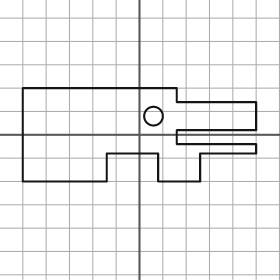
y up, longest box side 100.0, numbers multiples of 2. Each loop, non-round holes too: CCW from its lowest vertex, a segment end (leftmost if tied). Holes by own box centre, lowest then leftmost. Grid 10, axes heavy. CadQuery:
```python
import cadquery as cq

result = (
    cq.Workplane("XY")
    .moveTo(-50.0, -20.0)
    .lineTo(-14.0, -20.0)
    .lineTo(-14.0, -8.0)
    .lineTo(8.0, -8.0)
    .lineTo(8.0, -20.0)
    .lineTo(26.0, -20.0)
    .lineTo(26.0, -8.0)
    .lineTo(50.0, -8.0)
    .lineTo(50.0, -4.0)
    .lineTo(16.0, -4.0)
    .lineTo(16.0, 2.0)
    .lineTo(50.0, 2.0)
    .lineTo(50.0, 14.0)
    .lineTo(16.0, 14.0)
    .lineTo(16.0, 20.0)
    .lineTo(-50.0, 20.0)
    .close()
    .moveTo(6.0, 8.0)
    .circle(4.0)
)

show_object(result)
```